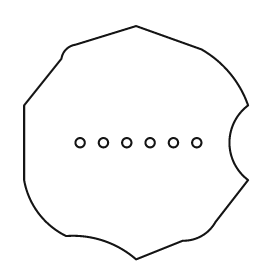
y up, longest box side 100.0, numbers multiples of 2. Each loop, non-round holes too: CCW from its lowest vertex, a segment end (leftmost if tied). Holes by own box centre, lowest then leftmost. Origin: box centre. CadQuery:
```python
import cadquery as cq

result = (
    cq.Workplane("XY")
    .moveTo(0.0, -50.0)
    .lineTo(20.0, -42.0)
    .threePointArc((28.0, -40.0), (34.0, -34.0))
    .lineTo(48.0, -16.0)
    .threePointArc((40.0, 0.0), (48.0, 16.0))
    .threePointArc((40.0, 30.0), (28.0, 40.0))
    .lineTo(0.0, 50.0)
    .lineTo(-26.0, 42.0)
    .threePointArc((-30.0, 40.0), (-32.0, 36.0))
    .lineTo(-48.0, 16.0)
    .lineTo(-48.0, -16.0)
    .threePointArc((-42.0, -30.0), (-30.0, -40.0))
    .threePointArc((-14.0, -42.0), (0.0, -50.0))
    .close()
    .moveTo(-24.0, 0.0)
    .circle(2.0)
    .moveTo(-14.0, 0.0)
    .circle(2.0)
    .moveTo(-4.0, 0.0)
    .circle(2.0)
    .moveTo(6.0, 0.0)
    .circle(2.0)
    .moveTo(16.0, 0.0)
    .circle(2.0)
    .moveTo(26.0, 0.0)
    .circle(2.0)
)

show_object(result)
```